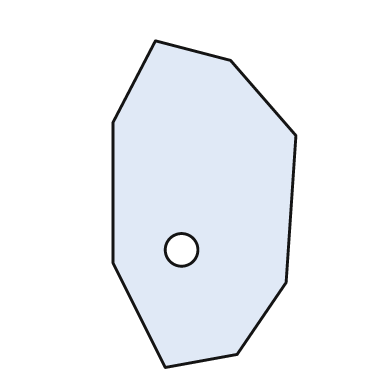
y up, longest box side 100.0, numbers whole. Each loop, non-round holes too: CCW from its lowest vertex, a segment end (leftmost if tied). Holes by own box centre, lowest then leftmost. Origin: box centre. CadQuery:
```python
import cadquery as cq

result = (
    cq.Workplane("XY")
    .moveTo(-12.0, -50.0)
    .lineTo(10.0, -46.0)
    .lineTo(25.0, -24.0)
    .lineTo(28.0, 21.0)
    .lineTo(8.0, 44.0)
    .lineTo(-15.0, 50.0)
    .lineTo(-28.0, 25.0)
    .lineTo(-28.0, -18.0)
    .close()
    .moveTo(-7.0, -14.0)
    .circle(5.0)
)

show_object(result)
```